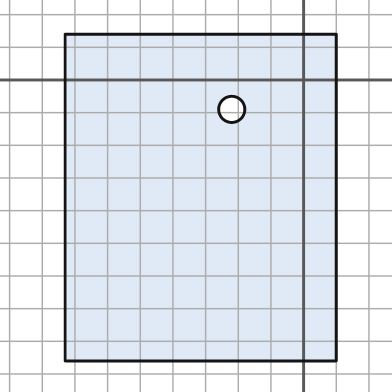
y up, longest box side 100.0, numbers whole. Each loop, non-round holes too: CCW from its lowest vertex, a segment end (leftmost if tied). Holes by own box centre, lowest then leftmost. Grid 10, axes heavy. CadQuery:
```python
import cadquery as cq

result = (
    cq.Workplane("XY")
    .moveTo(-73.0, -86.0)
    .lineTo(10.0, -86.0)
    .lineTo(10.0, 14.0)
    .lineTo(-73.0, 14.0)
    .close()
    .moveTo(-22.0, -9.0)
    .circle(4.0)
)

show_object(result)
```